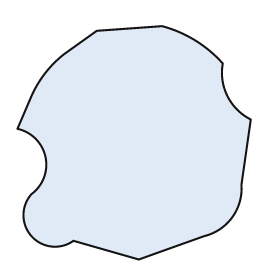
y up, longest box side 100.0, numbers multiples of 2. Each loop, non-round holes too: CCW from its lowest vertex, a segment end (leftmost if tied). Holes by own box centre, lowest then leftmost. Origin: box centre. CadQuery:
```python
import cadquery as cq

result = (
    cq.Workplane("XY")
    .moveTo(2.0, -50.0)
    .lineTo(30.0, -40.0)
    .threePointArc((42.0, -32.0), (46.0, -18.0))
    .lineTo(50.0, 10.0)
    .threePointArc((40.0, 20.0), (38.0, 34.0))
    .threePointArc((26.0, 44.0), (12.0, 50.0))
    .lineTo(-16.0, 48.0)
    .lineTo(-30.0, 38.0)
    .threePointArc((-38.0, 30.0), (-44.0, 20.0))
    .lineTo(-50.0, 6.0)
    .threePointArc((-38.0, -6.0), (-44.0, -22.0))
    .threePointArc((-44.0, -40.0), (-26.0, -42.0))
    .close()
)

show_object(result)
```